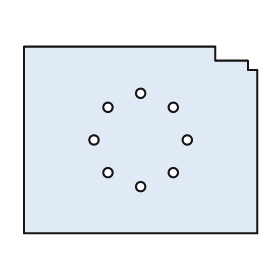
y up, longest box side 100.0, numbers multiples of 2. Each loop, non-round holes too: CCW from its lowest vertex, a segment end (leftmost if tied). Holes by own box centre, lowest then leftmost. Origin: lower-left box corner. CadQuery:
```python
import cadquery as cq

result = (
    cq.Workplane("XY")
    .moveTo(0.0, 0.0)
    .lineTo(100.0, 0.0)
    .lineTo(100.0, 70.0)
    .lineTo(96.0, 70.0)
    .lineTo(96.0, 74.0)
    .lineTo(82.0, 74.0)
    .lineTo(82.0, 80.0)
    .lineTo(0.0, 80.0)
    .close()
    .moveTo(50.0, 20.0)
    .circle(2.0)
    .moveTo(36.0, 26.0)
    .circle(2.0)
    .moveTo(64.0, 26.0)
    .circle(2.0)
    .moveTo(30.0, 40.0)
    .circle(2.0)
    .moveTo(70.0, 40.0)
    .circle(2.0)
    .moveTo(36.0, 54.0)
    .circle(2.0)
    .moveTo(64.0, 54.0)
    .circle(2.0)
    .moveTo(50.0, 60.0)
    .circle(2.0)
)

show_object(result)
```